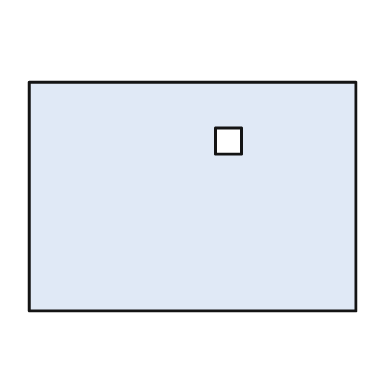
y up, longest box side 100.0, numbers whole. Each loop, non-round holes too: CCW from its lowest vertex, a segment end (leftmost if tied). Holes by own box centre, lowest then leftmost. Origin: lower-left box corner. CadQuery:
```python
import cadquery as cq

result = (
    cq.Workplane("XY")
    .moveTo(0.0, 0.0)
    .lineTo(100.0, 0.0)
    .lineTo(100.0, 70.0)
    .lineTo(0.0, 70.0)
    .close()
    .moveTo(57.0, 48.0)
    .lineTo(65.0, 48.0)
    .lineTo(65.0, 56.0)
    .lineTo(57.0, 56.0)
    .close()
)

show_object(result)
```